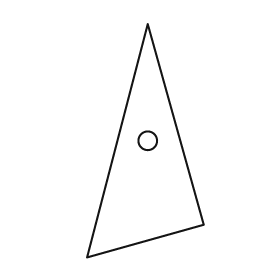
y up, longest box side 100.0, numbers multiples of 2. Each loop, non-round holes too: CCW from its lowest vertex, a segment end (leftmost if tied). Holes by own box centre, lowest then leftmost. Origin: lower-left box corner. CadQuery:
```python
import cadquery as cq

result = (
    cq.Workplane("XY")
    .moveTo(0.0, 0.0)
    .lineTo(50.0, 14.0)
    .lineTo(26.0, 100.0)
    .close()
    .moveTo(26.0, 50.0)
    .circle(4.0)
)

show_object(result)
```